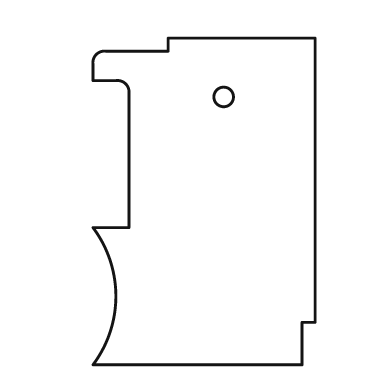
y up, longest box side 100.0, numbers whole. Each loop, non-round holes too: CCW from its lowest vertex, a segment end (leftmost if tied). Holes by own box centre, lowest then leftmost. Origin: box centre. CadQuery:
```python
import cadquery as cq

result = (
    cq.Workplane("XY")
    .moveTo(-34.0, -50.0)
    .lineTo(30.0, -50.0)
    .lineTo(30.0, -37.0)
    .lineTo(34.0, -37.0)
    .lineTo(34.0, 50.0)
    .lineTo(-11.0, 50.0)
    .lineTo(-11.0, 46.0)
    .lineTo(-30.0, 46.0)
    .threePointArc((-33.0, 45.0), (-34.0, 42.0))
    .lineTo(-34.0, 37.0)
    .lineTo(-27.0, 37.0)
    .threePointArc((-24.0, 36.0), (-23.0, 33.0))
    .lineTo(-23.0, -8.0)
    .lineTo(-34.0, -8.0)
    .threePointArc((-27.0, -29.0), (-34.0, -50.0))
    .close()
    .moveTo(6.0, 32.0)
    .circle(3.0)
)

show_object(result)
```